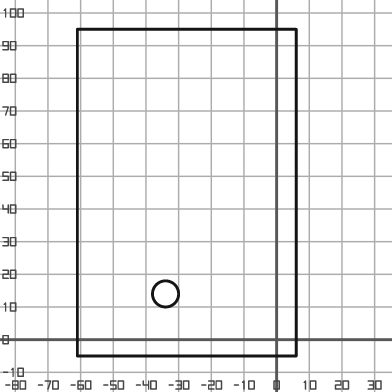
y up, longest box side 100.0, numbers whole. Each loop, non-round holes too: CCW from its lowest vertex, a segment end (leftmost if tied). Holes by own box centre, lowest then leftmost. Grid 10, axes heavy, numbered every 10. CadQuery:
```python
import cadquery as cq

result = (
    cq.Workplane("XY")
    .moveTo(-61.0, -5.0)
    .lineTo(6.0, -5.0)
    .lineTo(6.0, 95.0)
    .lineTo(-61.0, 95.0)
    .close()
    .moveTo(-34.0, 14.0)
    .circle(4.0)
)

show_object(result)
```